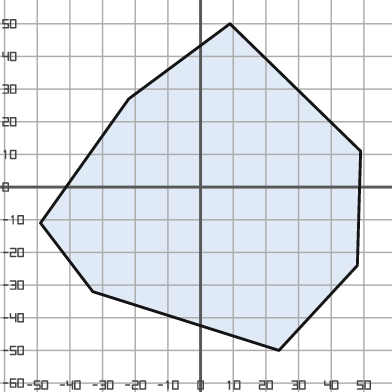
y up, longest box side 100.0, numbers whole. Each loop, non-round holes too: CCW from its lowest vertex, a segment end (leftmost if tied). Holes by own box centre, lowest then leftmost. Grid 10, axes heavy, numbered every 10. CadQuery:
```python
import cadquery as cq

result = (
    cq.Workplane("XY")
    .moveTo(24.0, -50.0)
    .lineTo(48.0, -24.0)
    .lineTo(49.0, 11.0)
    .lineTo(9.0, 50.0)
    .lineTo(-22.0, 27.0)
    .lineTo(-49.0, -11.0)
    .lineTo(-33.0, -32.0)
    .close()
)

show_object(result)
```